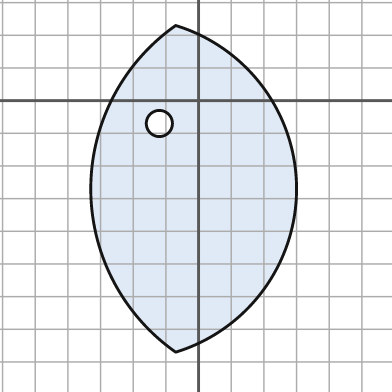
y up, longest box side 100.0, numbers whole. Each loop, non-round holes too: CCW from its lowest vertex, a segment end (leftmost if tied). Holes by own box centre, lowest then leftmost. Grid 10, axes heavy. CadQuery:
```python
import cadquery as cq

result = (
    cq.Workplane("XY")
    .moveTo(-7.0, -77.0)
    .threePointArc((30.0, -27.0), (-7.0, 23.0))
    .threePointArc((-33.0, -27.0), (-7.0, -77.0))
    .close()
    .moveTo(-12.0, -7.0)
    .circle(4.0)
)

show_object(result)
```